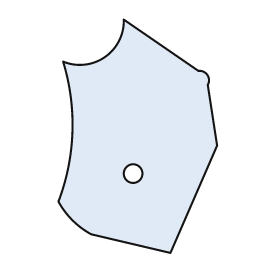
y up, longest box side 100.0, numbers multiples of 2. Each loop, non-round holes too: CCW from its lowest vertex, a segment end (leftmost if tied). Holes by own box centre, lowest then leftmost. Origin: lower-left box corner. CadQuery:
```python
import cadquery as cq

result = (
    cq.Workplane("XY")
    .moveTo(48.0, 0.0)
    .lineTo(68.0, 46.0)
    .lineTo(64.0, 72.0)
    .threePointArc((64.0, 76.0), (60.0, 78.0))
    .lineTo(28.0, 100.0)
    .threePointArc((20.0, 84.0), (2.0, 82.0))
    .threePointArc((6.0, 52.0), (0.0, 22.0))
    .threePointArc((6.0, 14.0), (14.0, 8.0))
    .close()
    .moveTo(32.0, 34.0)
    .circle(4.0)
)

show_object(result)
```